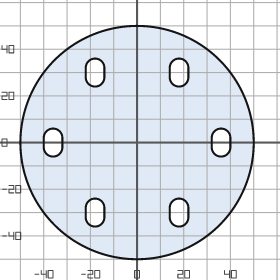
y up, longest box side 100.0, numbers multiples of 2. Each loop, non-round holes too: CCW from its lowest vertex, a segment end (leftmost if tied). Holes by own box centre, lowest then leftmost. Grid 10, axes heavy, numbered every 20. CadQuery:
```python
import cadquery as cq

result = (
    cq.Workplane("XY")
    .moveTo(0.0, 0.0)
    .circle(50.0)
    .moveTo(-22.0, -32.0)
    .threePointArc((-18.0, -36.0), (-14.0, -32.0))
    .lineTo(-14.0, -28.0)
    .threePointArc((-18.0, -24.0), (-22.0, -28.0))
    .close()
    .moveTo(14.0, -32.0)
    .threePointArc((18.0, -36.0), (22.0, -32.0))
    .lineTo(22.0, -28.0)
    .threePointArc((18.0, -24.0), (14.0, -28.0))
    .close()
    .moveTo(-40.0, -2.0)
    .threePointArc((-36.0, -6.0), (-32.0, -2.0))
    .lineTo(-32.0, 2.0)
    .threePointArc((-36.0, 6.0), (-40.0, 2.0))
    .close()
    .moveTo(32.0, -2.0)
    .threePointArc((36.0, -6.0), (40.0, -2.0))
    .lineTo(40.0, 2.0)
    .threePointArc((36.0, 6.0), (32.0, 2.0))
    .close()
    .moveTo(-22.0, 28.0)
    .threePointArc((-18.0, 24.0), (-14.0, 28.0))
    .lineTo(-14.0, 32.0)
    .threePointArc((-18.0, 36.0), (-22.0, 32.0))
    .close()
    .moveTo(14.0, 28.0)
    .threePointArc((18.0, 24.0), (22.0, 28.0))
    .lineTo(22.0, 32.0)
    .threePointArc((18.0, 36.0), (14.0, 32.0))
    .close()
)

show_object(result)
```